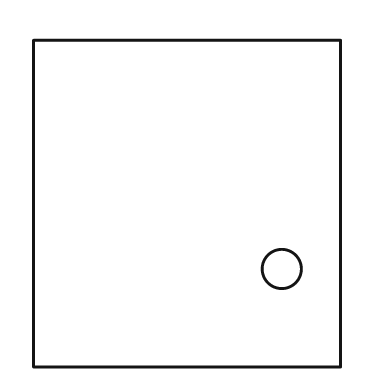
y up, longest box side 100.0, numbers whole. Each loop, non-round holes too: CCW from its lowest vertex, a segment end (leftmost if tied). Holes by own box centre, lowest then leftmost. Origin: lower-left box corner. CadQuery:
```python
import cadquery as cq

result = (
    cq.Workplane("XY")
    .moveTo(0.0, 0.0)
    .lineTo(94.0, 0.0)
    .lineTo(94.0, 100.0)
    .lineTo(0.0, 100.0)
    .close()
    .moveTo(76.0, 30.0)
    .circle(6.0)
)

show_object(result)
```